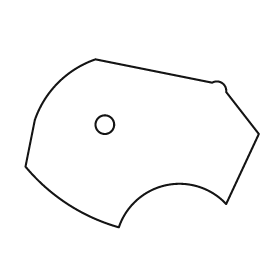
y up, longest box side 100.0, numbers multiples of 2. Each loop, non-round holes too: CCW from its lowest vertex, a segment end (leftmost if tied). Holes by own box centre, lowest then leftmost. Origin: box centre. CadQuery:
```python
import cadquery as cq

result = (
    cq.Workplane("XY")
    .moveTo(-10.0, -36.0)
    .threePointArc((10.0, -18.0), (36.0, -26.0))
    .lineTo(50.0, 4.0)
    .lineTo(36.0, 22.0)
    .threePointArc((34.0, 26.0), (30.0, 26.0))
    .lineTo(-20.0, 36.0)
    .threePointArc((-36.0, 26.0), (-46.0, 10.0))
    .lineTo(-50.0, -10.0)
    .threePointArc((-32.0, -26.0), (-10.0, -36.0))
    .close()
    .moveTo(-16.0, 8.0)
    .circle(4.0)
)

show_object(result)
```